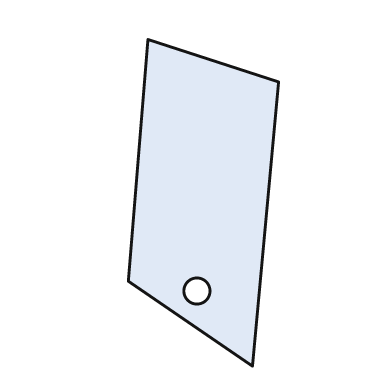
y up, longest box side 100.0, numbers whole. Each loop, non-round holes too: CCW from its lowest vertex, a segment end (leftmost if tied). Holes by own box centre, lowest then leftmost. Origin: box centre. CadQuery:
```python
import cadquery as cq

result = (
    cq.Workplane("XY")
    .moveTo(15.0, -50.0)
    .lineTo(23.0, 37.0)
    .lineTo(-17.0, 50.0)
    .lineTo(-23.0, -24.0)
    .close()
    .moveTo(-2.0, -27.0)
    .circle(4.0)
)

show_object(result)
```